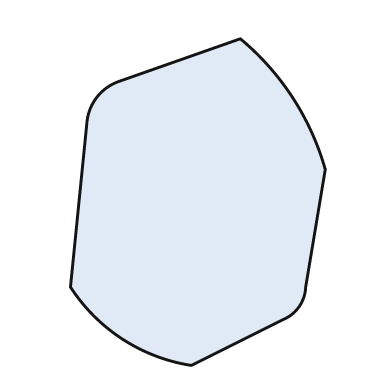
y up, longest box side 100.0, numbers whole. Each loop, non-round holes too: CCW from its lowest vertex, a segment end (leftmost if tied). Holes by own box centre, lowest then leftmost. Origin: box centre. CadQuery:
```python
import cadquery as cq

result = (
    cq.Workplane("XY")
    .moveTo(-2.0, -50.0)
    .lineTo(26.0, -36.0)
    .threePointArc((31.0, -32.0), (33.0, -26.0))
    .lineTo(39.0, 10.0)
    .threePointArc((29.0, 32.0), (13.0, 50.0))
    .lineTo(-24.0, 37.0)
    .threePointArc((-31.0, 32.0), (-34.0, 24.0))
    .lineTo(-39.0, -26.0)
    .threePointArc((-23.0, -42.0), (-2.0, -50.0))
    .close()
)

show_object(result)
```